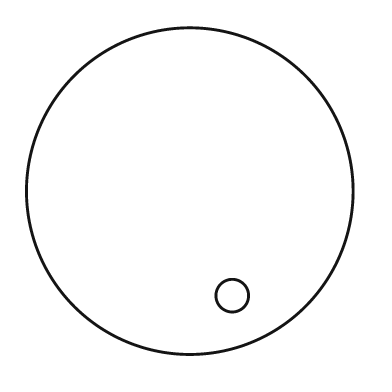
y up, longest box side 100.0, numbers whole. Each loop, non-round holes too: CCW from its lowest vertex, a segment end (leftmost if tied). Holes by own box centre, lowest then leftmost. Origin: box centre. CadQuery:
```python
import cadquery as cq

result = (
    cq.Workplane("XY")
    .moveTo(0.0, 0.0)
    .circle(50.0)
    .moveTo(13.0, -32.0)
    .circle(5.0)
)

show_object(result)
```